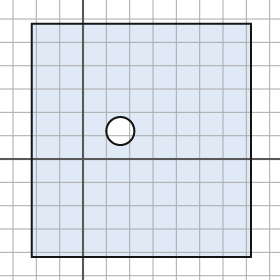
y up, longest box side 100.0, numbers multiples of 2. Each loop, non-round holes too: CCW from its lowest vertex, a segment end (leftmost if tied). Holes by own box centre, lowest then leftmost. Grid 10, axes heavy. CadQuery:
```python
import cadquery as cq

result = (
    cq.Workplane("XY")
    .moveTo(-22.0, -42.0)
    .lineTo(72.0, -42.0)
    .lineTo(72.0, 58.0)
    .lineTo(-22.0, 58.0)
    .close()
    .moveTo(16.0, 12.0)
    .circle(6.0)
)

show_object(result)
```